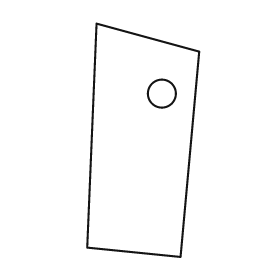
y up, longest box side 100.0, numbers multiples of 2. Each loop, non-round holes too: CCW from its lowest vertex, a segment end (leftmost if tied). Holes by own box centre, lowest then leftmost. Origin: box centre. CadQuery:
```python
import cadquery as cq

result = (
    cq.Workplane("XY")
    .moveTo(16.0, -50.0)
    .lineTo(24.0, 38.0)
    .lineTo(-20.0, 50.0)
    .lineTo(-24.0, -46.0)
    .close()
    .moveTo(8.0, 20.0)
    .circle(6.0)
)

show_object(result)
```